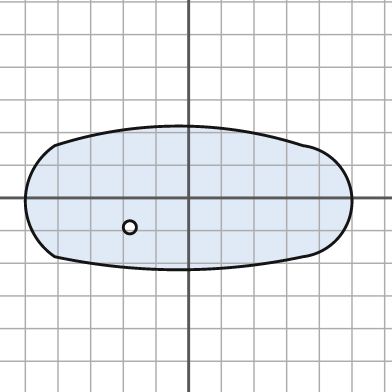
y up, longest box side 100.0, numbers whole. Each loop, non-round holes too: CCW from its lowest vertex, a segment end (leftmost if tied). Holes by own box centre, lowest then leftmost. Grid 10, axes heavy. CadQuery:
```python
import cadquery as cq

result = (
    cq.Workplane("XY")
    .moveTo(-41.0, -18.0)
    .threePointArc((-3.0, -22.0), (35.0, -18.0))
    .threePointArc((50.0, -1.0), (35.0, 16.0))
    .threePointArc((-3.0, 22.0), (-41.0, 16.0))
    .threePointArc((-50.0, -1.0), (-41.0, -18.0))
    .close()
    .moveTo(-18.0, -9.0)
    .circle(2.0)
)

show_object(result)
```